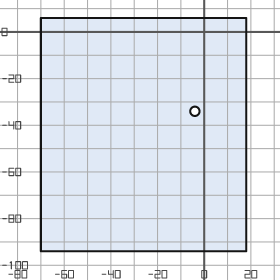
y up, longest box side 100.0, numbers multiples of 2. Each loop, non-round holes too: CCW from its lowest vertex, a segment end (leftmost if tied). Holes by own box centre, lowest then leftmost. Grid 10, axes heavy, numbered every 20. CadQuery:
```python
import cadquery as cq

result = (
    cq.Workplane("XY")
    .moveTo(-70.0, -94.0)
    .lineTo(18.0, -94.0)
    .lineTo(18.0, 6.0)
    .lineTo(-70.0, 6.0)
    .close()
    .moveTo(-4.0, -34.0)
    .circle(2.0)
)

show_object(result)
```